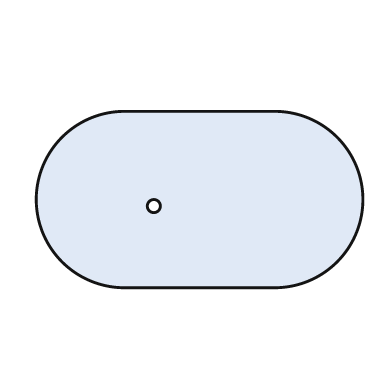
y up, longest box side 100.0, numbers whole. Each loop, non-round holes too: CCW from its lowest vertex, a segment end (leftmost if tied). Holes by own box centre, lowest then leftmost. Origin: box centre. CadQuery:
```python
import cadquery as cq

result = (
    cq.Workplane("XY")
    .moveTo(-23.0, -27.0)
    .lineTo(23.0, -27.0)
    .threePointArc((50.0, 0.0), (23.0, 27.0))
    .lineTo(-23.0, 27.0)
    .threePointArc((-50.0, 0.0), (-23.0, -27.0))
    .close()
    .moveTo(-14.0, -2.0)
    .circle(2.0)
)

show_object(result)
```